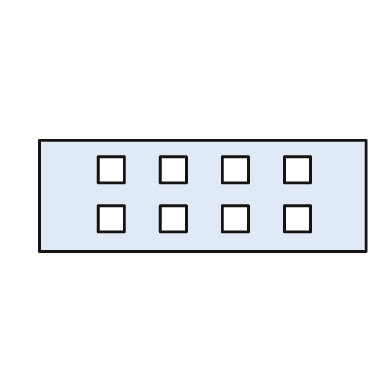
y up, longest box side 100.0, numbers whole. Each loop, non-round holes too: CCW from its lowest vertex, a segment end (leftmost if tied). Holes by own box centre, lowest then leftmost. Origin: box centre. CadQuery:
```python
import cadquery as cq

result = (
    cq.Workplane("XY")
    .moveTo(-50.0, -17.0)
    .lineTo(50.0, -17.0)
    .lineTo(50.0, 17.0)
    .lineTo(-50.0, 17.0)
    .close()
    .moveTo(-32.0, -11.0)
    .lineTo(-24.0, -11.0)
    .lineTo(-24.0, -3.0)
    .lineTo(-32.0, -3.0)
    .close()
    .moveTo(-13.0, -11.0)
    .lineTo(-5.0, -11.0)
    .lineTo(-5.0, -3.0)
    .lineTo(-13.0, -3.0)
    .close()
    .moveTo(6.0, -11.0)
    .lineTo(14.0, -11.0)
    .lineTo(14.0, -3.0)
    .lineTo(6.0, -3.0)
    .close()
    .moveTo(25.0, -11.0)
    .lineTo(33.0, -11.0)
    .lineTo(33.0, -3.0)
    .lineTo(25.0, -3.0)
    .close()
    .moveTo(-32.0, 4.0)
    .lineTo(-24.0, 4.0)
    .lineTo(-24.0, 12.0)
    .lineTo(-32.0, 12.0)
    .close()
    .moveTo(-13.0, 4.0)
    .lineTo(-5.0, 4.0)
    .lineTo(-5.0, 12.0)
    .lineTo(-13.0, 12.0)
    .close()
    .moveTo(6.0, 4.0)
    .lineTo(14.0, 4.0)
    .lineTo(14.0, 12.0)
    .lineTo(6.0, 12.0)
    .close()
    .moveTo(25.0, 4.0)
    .lineTo(33.0, 4.0)
    .lineTo(33.0, 12.0)
    .lineTo(25.0, 12.0)
    .close()
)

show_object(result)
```